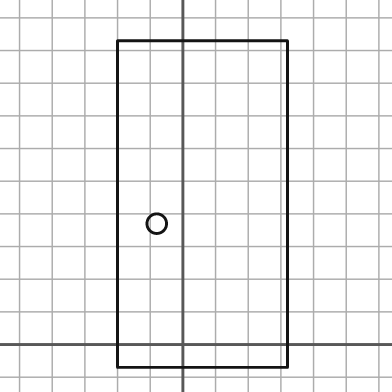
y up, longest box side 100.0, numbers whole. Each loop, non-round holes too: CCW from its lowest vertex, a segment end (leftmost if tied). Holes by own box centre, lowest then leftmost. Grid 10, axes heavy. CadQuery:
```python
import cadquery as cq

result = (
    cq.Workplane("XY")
    .moveTo(-20.0, -7.0)
    .lineTo(32.0, -7.0)
    .lineTo(32.0, 93.0)
    .lineTo(-20.0, 93.0)
    .close()
    .moveTo(-8.0, 37.0)
    .circle(3.0)
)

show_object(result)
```